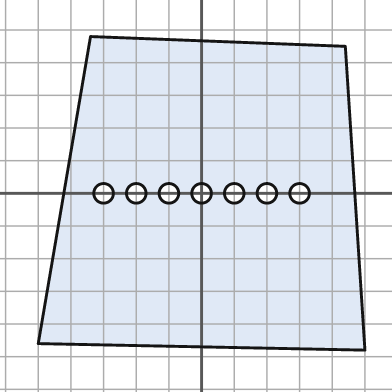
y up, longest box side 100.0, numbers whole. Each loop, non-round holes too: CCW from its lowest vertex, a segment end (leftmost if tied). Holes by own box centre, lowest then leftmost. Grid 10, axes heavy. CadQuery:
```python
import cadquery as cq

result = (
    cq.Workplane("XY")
    .moveTo(50.0, -48.0)
    .lineTo(44.0, 45.0)
    .lineTo(-34.0, 48.0)
    .lineTo(-50.0, -46.0)
    .close()
    .moveTo(-30.0, 0.0)
    .circle(3.0)
    .moveTo(-20.0, 0.0)
    .circle(3.0)
    .moveTo(-10.0, 0.0)
    .circle(3.0)
    .moveTo(0.0, 0.0)
    .circle(3.0)
    .moveTo(10.0, 0.0)
    .circle(3.0)
    .moveTo(20.0, 0.0)
    .circle(3.0)
    .moveTo(30.0, 0.0)
    .circle(3.0)
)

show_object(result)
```